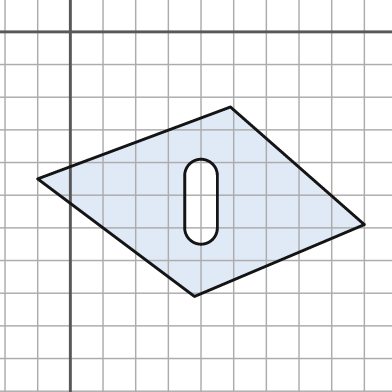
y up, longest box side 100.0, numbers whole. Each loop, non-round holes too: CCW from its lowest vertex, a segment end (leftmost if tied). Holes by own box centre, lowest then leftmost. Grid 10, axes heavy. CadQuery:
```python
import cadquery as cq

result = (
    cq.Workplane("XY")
    .moveTo(38.0, -81.0)
    .lineTo(90.0, -59.0)
    .lineTo(49.0, -23.0)
    .lineTo(-10.0, -45.0)
    .close()
    .moveTo(35.0, -60.0)
    .threePointArc((40.0, -65.0), (45.0, -60.0))
    .lineTo(45.0, -44.0)
    .threePointArc((40.0, -39.0), (35.0, -44.0))
    .close()
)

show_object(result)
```